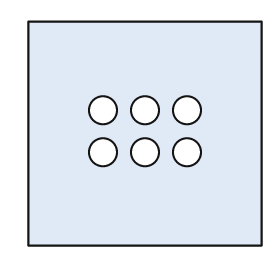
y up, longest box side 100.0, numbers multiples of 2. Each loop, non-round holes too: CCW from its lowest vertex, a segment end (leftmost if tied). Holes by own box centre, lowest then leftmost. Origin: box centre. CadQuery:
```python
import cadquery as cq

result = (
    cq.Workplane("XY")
    .moveTo(-50.0, -48.0)
    .lineTo(50.0, -48.0)
    .lineTo(50.0, 48.0)
    .lineTo(-50.0, 48.0)
    .close()
    .moveTo(-18.0, -8.0)
    .circle(6.0)
    .moveTo(0.0, -8.0)
    .circle(6.0)
    .moveTo(18.0, -8.0)
    .circle(6.0)
    .moveTo(-18.0, 10.0)
    .circle(6.0)
    .moveTo(0.0, 10.0)
    .circle(6.0)
    .moveTo(18.0, 10.0)
    .circle(6.0)
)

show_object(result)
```